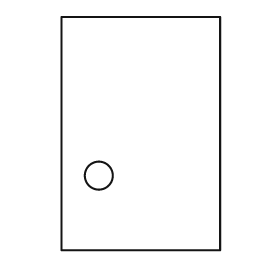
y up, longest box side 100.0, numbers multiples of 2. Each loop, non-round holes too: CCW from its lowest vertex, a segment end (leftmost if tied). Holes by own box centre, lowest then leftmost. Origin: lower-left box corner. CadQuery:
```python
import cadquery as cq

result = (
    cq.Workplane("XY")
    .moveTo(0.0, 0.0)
    .lineTo(68.0, 0.0)
    .lineTo(68.0, 100.0)
    .lineTo(0.0, 100.0)
    .close()
    .moveTo(16.0, 32.0)
    .circle(6.0)
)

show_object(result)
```